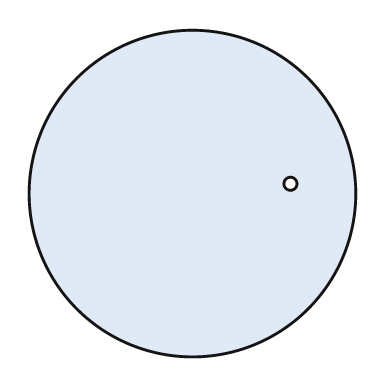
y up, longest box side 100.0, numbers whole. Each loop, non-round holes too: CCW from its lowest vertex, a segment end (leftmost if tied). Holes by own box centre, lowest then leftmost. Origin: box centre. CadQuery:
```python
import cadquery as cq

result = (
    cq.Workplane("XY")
    .moveTo(0.0, 0.0)
    .circle(50.0)
    .moveTo(30.0, 3.0)
    .circle(2.0)
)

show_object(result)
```